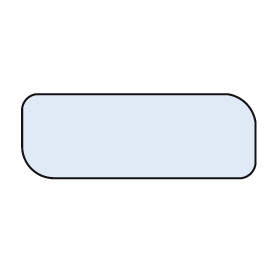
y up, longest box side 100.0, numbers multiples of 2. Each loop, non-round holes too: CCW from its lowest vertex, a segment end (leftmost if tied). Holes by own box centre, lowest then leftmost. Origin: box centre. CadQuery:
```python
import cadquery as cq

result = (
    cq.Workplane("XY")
    .moveTo(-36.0, -18.0)
    .lineTo(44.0, -18.0)
    .threePointArc((48.0, -16.0), (50.0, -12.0))
    .lineTo(50.0, 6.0)
    .threePointArc((46.0, 14.0), (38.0, 18.0))
    .lineTo(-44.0, 18.0)
    .threePointArc((-48.0, 16.0), (-50.0, 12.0))
    .lineTo(-50.0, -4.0)
    .threePointArc((-46.0, -14.0), (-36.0, -18.0))
    .close()
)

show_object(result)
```